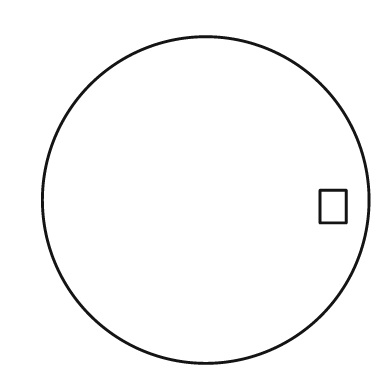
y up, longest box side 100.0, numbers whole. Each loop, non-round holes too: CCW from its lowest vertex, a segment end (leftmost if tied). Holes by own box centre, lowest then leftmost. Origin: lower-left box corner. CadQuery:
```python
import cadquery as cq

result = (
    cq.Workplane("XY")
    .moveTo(50.0, 50.0)
    .circle(50.0)
    .moveTo(85.0, 43.0)
    .lineTo(93.0, 43.0)
    .lineTo(93.0, 53.0)
    .lineTo(85.0, 53.0)
    .close()
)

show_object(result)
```